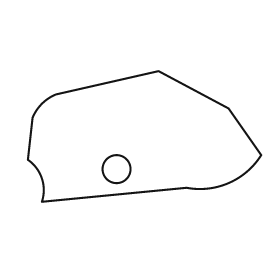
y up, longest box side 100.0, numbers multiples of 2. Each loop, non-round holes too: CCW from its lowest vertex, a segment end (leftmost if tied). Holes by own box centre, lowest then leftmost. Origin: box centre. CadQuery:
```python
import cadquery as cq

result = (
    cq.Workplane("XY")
    .moveTo(-44.0, -28.0)
    .lineTo(18.0, -22.0)
    .threePointArc((36.0, -20.0), (50.0, -8.0))
    .lineTo(36.0, 12.0)
    .lineTo(6.0, 28.0)
    .lineTo(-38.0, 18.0)
    .threePointArc((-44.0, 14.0), (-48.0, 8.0))
    .lineTo(-50.0, -10.0)
    .threePointArc((-44.0, -18.0), (-44.0, -28.0))
    .close()
    .moveTo(-12.0, -14.0)
    .circle(6.0)
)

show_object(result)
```